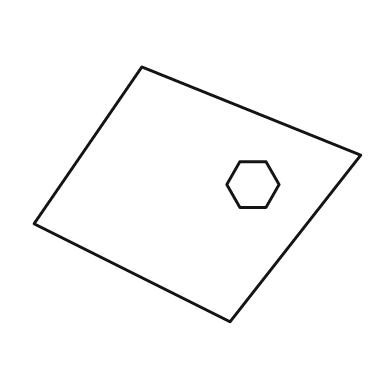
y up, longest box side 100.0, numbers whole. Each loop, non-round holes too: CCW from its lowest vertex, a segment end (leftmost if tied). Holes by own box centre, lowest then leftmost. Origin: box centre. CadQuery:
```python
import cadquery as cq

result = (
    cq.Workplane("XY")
    .moveTo(10.0, -39.0)
    .lineTo(50.0, 12.0)
    .lineTo(-17.0, 39.0)
    .lineTo(-50.0, -9.0)
    .close()
    .moveTo(13.0, -4.0)
    .lineTo(21.0, -4.0)
    .lineTo(25.0, 3.0)
    .lineTo(21.0, 10.0)
    .lineTo(13.0, 10.0)
    .lineTo(9.0, 3.0)
    .close()
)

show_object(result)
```